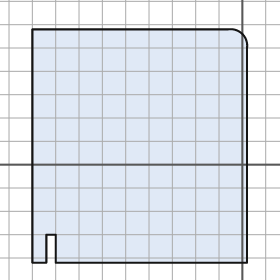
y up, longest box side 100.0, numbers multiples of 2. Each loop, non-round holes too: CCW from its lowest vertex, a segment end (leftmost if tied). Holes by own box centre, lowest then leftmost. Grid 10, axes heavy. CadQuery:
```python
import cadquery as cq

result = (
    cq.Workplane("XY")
    .moveTo(-90.0, -42.0)
    .lineTo(-84.0, -42.0)
    .lineTo(-84.0, -30.0)
    .lineTo(-80.0, -30.0)
    .lineTo(-80.0, -42.0)
    .lineTo(2.0, -42.0)
    .lineTo(2.0, 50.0)
    .threePointArc((0.0, 56.0), (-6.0, 58.0))
    .lineTo(-90.0, 58.0)
    .close()
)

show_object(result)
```